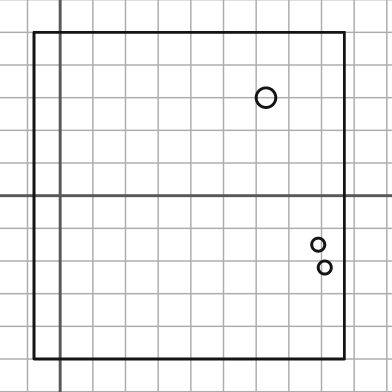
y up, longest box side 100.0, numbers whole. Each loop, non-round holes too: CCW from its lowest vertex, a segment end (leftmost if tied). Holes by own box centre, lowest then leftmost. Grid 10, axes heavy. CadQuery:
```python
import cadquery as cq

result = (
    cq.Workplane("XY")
    .moveTo(-8.0, -50.0)
    .lineTo(87.0, -50.0)
    .lineTo(87.0, 50.0)
    .lineTo(-8.0, 50.0)
    .close()
    .moveTo(81.0, -22.0)
    .circle(2.0)
    .moveTo(79.0, -15.0)
    .circle(2.0)
    .moveTo(63.0, 30.0)
    .circle(3.0)
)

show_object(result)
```